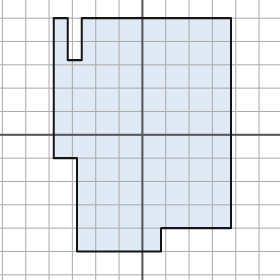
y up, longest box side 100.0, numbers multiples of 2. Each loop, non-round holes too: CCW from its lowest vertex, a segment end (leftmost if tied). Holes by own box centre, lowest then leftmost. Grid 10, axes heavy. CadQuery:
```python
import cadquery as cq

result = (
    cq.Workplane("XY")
    .moveTo(-28.0, -50.0)
    .lineTo(8.0, -50.0)
    .lineTo(8.0, -40.0)
    .lineTo(38.0, -40.0)
    .lineTo(38.0, 50.0)
    .lineTo(-26.0, 50.0)
    .lineTo(-26.0, 32.0)
    .lineTo(-32.0, 32.0)
    .lineTo(-32.0, 50.0)
    .lineTo(-38.0, 50.0)
    .lineTo(-38.0, -10.0)
    .lineTo(-28.0, -10.0)
    .close()
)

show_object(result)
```